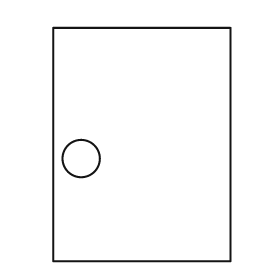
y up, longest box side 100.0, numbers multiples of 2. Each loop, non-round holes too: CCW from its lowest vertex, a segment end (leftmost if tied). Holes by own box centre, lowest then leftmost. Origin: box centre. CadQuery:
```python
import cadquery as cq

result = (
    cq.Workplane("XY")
    .moveTo(-38.0, -50.0)
    .lineTo(38.0, -50.0)
    .lineTo(38.0, 50.0)
    .lineTo(-38.0, 50.0)
    .close()
    .moveTo(-26.0, -6.0)
    .circle(8.0)
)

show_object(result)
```